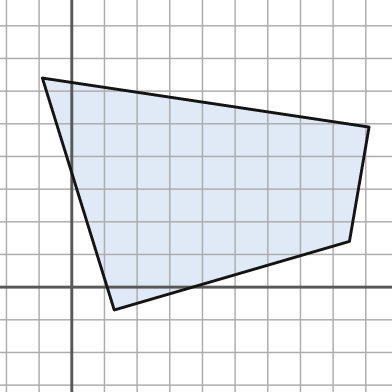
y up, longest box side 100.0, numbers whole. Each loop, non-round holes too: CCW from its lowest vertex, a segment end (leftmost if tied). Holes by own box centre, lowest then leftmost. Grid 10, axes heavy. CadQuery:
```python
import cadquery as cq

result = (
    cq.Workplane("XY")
    .moveTo(13.0, -7.0)
    .lineTo(85.0, 14.0)
    .lineTo(91.0, 49.0)
    .lineTo(-9.0, 64.0)
    .close()
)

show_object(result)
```